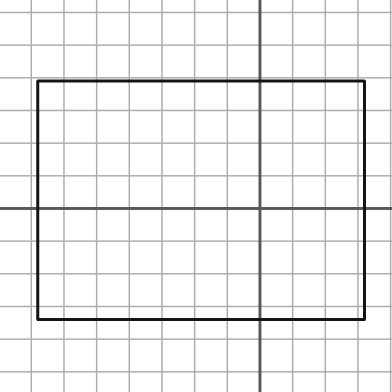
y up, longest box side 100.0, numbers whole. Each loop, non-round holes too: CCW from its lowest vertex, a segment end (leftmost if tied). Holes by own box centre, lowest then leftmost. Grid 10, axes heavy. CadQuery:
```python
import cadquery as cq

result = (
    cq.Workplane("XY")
    .moveTo(-68.0, -34.0)
    .lineTo(32.0, -34.0)
    .lineTo(32.0, 39.0)
    .lineTo(-68.0, 39.0)
    .close()
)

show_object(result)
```